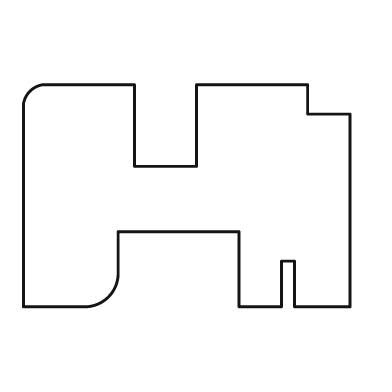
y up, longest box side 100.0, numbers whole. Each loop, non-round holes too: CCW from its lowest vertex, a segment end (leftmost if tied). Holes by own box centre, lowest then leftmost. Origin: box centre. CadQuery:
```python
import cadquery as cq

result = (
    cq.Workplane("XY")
    .moveTo(-50.0, -34.0)
    .lineTo(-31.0, -34.0)
    .threePointArc((-24.0, -31.0), (-21.0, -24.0))
    .lineTo(-21.0, -11.0)
    .lineTo(16.0, -11.0)
    .lineTo(16.0, -34.0)
    .lineTo(29.0, -34.0)
    .lineTo(29.0, -20.0)
    .lineTo(33.0, -20.0)
    .lineTo(33.0, -34.0)
    .lineTo(50.0, -34.0)
    .lineTo(50.0, 25.0)
    .lineTo(37.0, 25.0)
    .lineTo(37.0, 34.0)
    .lineTo(3.0, 34.0)
    .lineTo(3.0, 9.0)
    .lineTo(-16.0, 9.0)
    .lineTo(-16.0, 34.0)
    .lineTo(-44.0, 34.0)
    .threePointArc((-48.0, 32.0), (-50.0, 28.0))
    .close()
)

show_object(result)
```